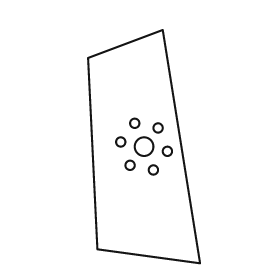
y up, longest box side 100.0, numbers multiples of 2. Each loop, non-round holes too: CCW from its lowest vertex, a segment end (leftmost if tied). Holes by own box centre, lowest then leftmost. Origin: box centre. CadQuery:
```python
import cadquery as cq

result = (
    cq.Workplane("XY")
    .moveTo(24.0, -50.0)
    .lineTo(8.0, 50.0)
    .lineTo(-24.0, 38.0)
    .lineTo(-20.0, -44.0)
    .close()
    .moveTo(4.0, -10.0)
    .circle(2.0)
    .moveTo(-6.0, -8.0)
    .circle(2.0)
    .moveTo(10.0, -2.0)
    .circle(2.0)
    .moveTo(0.0, 0.0)
    .circle(4.0)
    .moveTo(-10.0, 2.0)
    .circle(2.0)
    .moveTo(6.0, 8.0)
    .circle(2.0)
    .moveTo(-4.0, 10.0)
    .circle(2.0)
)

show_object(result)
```